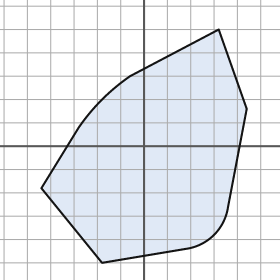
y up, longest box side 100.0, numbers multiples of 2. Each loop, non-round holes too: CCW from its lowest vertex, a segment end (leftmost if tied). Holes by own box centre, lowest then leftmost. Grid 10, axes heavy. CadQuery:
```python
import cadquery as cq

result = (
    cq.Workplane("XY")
    .moveTo(-18.0, -50.0)
    .lineTo(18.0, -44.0)
    .threePointArc((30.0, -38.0), (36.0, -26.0))
    .lineTo(44.0, 16.0)
    .lineTo(32.0, 50.0)
    .lineTo(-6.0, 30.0)
    .threePointArc((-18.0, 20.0), (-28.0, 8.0))
    .lineTo(-44.0, -18.0)
    .close()
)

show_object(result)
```